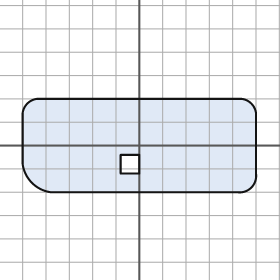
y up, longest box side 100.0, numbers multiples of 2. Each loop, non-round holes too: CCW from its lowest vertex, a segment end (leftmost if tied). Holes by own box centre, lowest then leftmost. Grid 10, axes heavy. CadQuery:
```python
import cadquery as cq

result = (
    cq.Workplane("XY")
    .moveTo(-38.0, -20.0)
    .lineTo(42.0, -20.0)
    .threePointArc((48.0, -18.0), (50.0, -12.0))
    .lineTo(50.0, 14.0)
    .threePointArc((48.0, 18.0), (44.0, 20.0))
    .lineTo(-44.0, 20.0)
    .threePointArc((-48.0, 18.0), (-50.0, 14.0))
    .lineTo(-50.0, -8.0)
    .threePointArc((-46.0, -16.0), (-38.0, -20.0))
    .close()
    .moveTo(-8.0, -12.0)
    .lineTo(0.0, -12.0)
    .lineTo(0.0, -4.0)
    .lineTo(-8.0, -4.0)
    .close()
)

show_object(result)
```